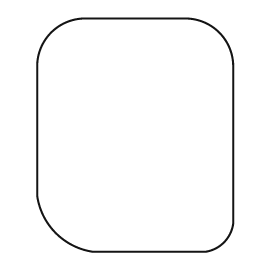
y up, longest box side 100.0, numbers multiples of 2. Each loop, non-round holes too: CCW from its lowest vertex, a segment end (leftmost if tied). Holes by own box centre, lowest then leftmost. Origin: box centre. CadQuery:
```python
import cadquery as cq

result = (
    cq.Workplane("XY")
    .moveTo(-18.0, -50.0)
    .lineTo(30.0, -50.0)
    .threePointArc((38.0, -46.0), (42.0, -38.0))
    .lineTo(42.0, 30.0)
    .threePointArc((36.0, 44.0), (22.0, 50.0))
    .lineTo(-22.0, 50.0)
    .threePointArc((-36.0, 44.0), (-42.0, 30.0))
    .lineTo(-42.0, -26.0)
    .threePointArc((-34.0, -42.0), (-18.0, -50.0))
    .close()
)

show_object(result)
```